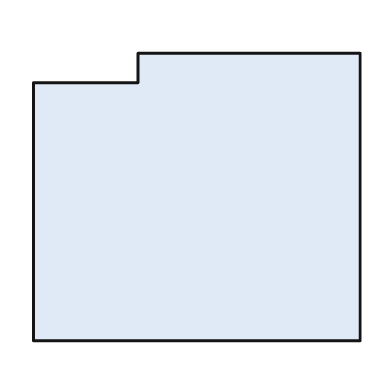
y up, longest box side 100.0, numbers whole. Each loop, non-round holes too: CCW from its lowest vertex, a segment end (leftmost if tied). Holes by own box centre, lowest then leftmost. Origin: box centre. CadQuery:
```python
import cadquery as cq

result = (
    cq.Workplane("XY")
    .moveTo(-50.0, -44.0)
    .lineTo(50.0, -44.0)
    .lineTo(50.0, 44.0)
    .lineTo(-18.0, 44.0)
    .lineTo(-18.0, 35.0)
    .lineTo(-50.0, 35.0)
    .close()
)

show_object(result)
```